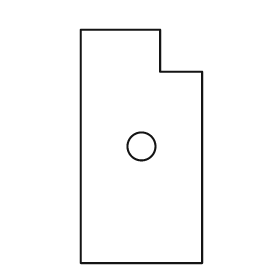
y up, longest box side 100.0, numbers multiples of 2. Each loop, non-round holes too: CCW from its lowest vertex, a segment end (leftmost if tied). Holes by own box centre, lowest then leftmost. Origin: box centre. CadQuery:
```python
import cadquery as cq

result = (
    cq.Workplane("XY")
    .moveTo(-26.0, -50.0)
    .lineTo(26.0, -50.0)
    .lineTo(26.0, 32.0)
    .lineTo(8.0, 32.0)
    .lineTo(8.0, 50.0)
    .lineTo(-26.0, 50.0)
    .close()
    .moveTo(0.0, 0.0)
    .circle(6.0)
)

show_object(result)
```